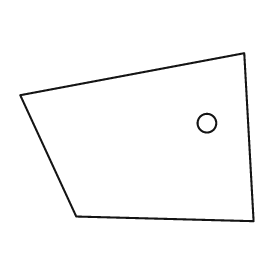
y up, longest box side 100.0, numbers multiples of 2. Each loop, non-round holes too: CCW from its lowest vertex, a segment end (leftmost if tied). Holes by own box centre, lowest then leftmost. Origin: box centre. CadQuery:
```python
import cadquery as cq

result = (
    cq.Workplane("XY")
    .moveTo(50.0, -36.0)
    .lineTo(46.0, 36.0)
    .lineTo(-50.0, 18.0)
    .lineTo(-26.0, -34.0)
    .close()
    .moveTo(30.0, 6.0)
    .circle(4.0)
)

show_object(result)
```